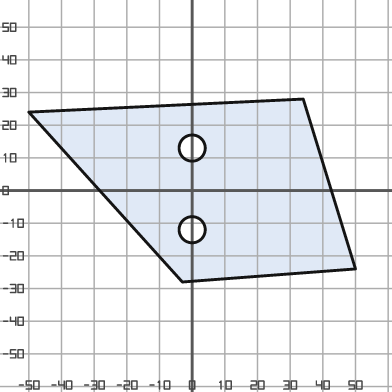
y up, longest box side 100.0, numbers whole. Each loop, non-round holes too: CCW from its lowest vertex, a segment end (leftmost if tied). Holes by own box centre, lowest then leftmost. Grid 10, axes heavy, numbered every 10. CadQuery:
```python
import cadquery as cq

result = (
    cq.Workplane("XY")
    .moveTo(-3.0, -28.0)
    .lineTo(50.0, -24.0)
    .lineTo(34.0, 28.0)
    .lineTo(-50.0, 24.0)
    .close()
    .moveTo(0.0, -12.0)
    .circle(4.0)
    .moveTo(0.0, 13.0)
    .circle(4.0)
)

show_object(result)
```